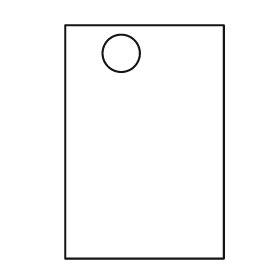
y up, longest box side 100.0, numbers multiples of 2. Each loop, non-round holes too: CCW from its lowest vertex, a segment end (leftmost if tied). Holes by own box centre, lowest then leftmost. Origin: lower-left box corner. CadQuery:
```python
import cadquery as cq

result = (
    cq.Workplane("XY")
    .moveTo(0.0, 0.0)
    .lineTo(68.0, 0.0)
    .lineTo(68.0, 100.0)
    .lineTo(0.0, 100.0)
    .close()
    .moveTo(24.0, 88.0)
    .circle(8.0)
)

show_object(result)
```